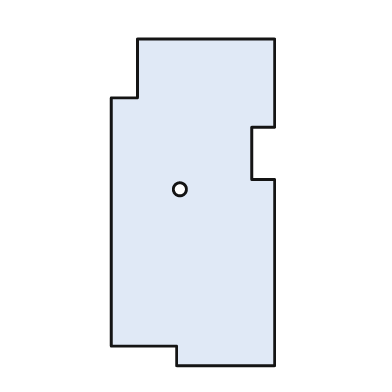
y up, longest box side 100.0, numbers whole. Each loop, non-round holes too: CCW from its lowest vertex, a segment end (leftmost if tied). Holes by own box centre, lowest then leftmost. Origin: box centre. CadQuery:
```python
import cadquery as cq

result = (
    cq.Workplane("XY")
    .moveTo(-5.0, -50.0)
    .lineTo(25.0, -50.0)
    .lineTo(25.0, 7.0)
    .lineTo(18.0, 7.0)
    .lineTo(18.0, 23.0)
    .lineTo(25.0, 23.0)
    .lineTo(25.0, 50.0)
    .lineTo(-17.0, 50.0)
    .lineTo(-17.0, 32.0)
    .lineTo(-25.0, 32.0)
    .lineTo(-25.0, -44.0)
    .lineTo(-5.0, -44.0)
    .close()
    .moveTo(-4.0, 4.0)
    .circle(2.0)
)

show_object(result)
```